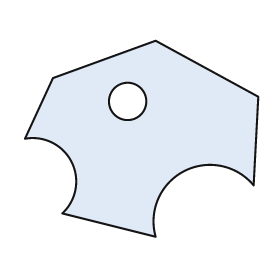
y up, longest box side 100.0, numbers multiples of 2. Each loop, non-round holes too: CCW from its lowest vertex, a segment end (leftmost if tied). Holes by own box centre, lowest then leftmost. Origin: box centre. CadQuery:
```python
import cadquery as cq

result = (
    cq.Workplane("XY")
    .moveTo(6.0, -42.0)
    .threePointArc((18.0, -14.0), (48.0, -20.0))
    .lineTo(50.0, 18.0)
    .lineTo(6.0, 42.0)
    .lineTo(-38.0, 26.0)
    .lineTo(-50.0, 0.0)
    .threePointArc((-30.0, -10.0), (-34.0, -32.0))
    .close()
    .moveTo(-6.0, 16.0)
    .circle(8.0)
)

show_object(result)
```